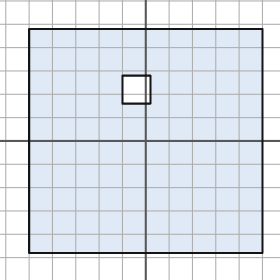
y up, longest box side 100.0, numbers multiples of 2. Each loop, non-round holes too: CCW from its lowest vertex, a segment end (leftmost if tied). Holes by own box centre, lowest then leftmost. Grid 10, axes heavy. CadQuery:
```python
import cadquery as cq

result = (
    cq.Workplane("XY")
    .moveTo(-50.0, -48.0)
    .lineTo(50.0, -48.0)
    .lineTo(50.0, 48.0)
    .lineTo(-50.0, 48.0)
    .close()
    .moveTo(-10.0, 16.0)
    .lineTo(2.0, 16.0)
    .lineTo(2.0, 28.0)
    .lineTo(-10.0, 28.0)
    .close()
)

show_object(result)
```